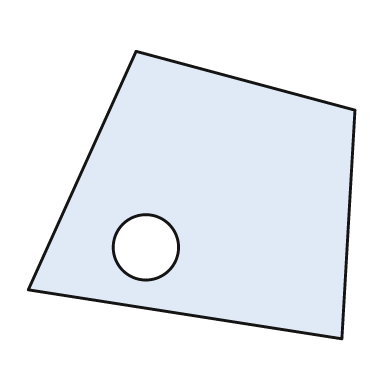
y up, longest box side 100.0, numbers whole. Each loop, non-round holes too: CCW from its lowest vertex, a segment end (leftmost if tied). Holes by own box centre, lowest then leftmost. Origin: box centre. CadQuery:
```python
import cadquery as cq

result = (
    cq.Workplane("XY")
    .moveTo(46.0, -44.0)
    .lineTo(50.0, 26.0)
    .lineTo(-17.0, 44.0)
    .lineTo(-50.0, -29.0)
    .close()
    .moveTo(-14.0, -16.0)
    .circle(10.0)
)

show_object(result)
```